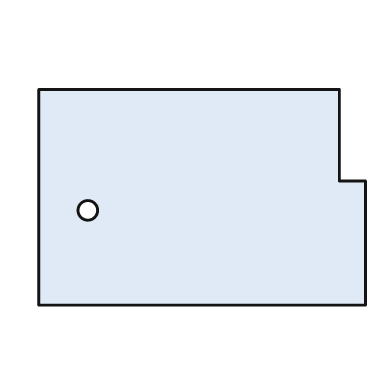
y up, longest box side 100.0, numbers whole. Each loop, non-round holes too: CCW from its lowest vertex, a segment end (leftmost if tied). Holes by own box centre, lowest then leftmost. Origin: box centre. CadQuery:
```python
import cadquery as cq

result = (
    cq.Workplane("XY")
    .moveTo(-50.0, -33.0)
    .lineTo(50.0, -33.0)
    .lineTo(50.0, 5.0)
    .lineTo(42.0, 5.0)
    .lineTo(42.0, 33.0)
    .lineTo(-50.0, 33.0)
    .close()
    .moveTo(-35.0, -4.0)
    .circle(3.0)
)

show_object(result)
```